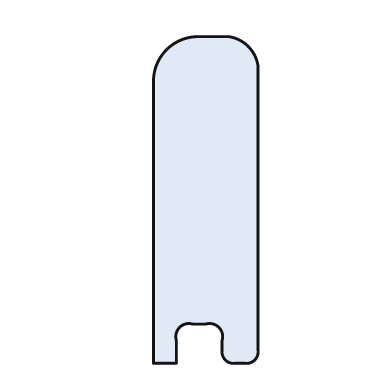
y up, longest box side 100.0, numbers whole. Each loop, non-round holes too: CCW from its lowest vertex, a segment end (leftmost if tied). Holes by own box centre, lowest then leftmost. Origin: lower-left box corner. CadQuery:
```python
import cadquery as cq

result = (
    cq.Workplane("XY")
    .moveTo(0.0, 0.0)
    .lineTo(7.0, 0.0)
    .lineTo(7.0, 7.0)
    .threePointArc((8.0, 11.0), (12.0, 12.0))
    .lineTo(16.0, 12.0)
    .threePointArc((20.0, 11.0), (21.0, 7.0))
    .lineTo(21.0, 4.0)
    .threePointArc((22.0, 1.0), (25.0, 0.0))
    .lineTo(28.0, 0.0)
    .threePointArc((31.0, 1.0), (32.0, 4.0))
    .lineTo(32.0, 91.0)
    .threePointArc((29.0, 97.0), (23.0, 100.0))
    .lineTo(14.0, 100.0)
    .threePointArc((4.0, 96.0), (0.0, 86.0))
    .close()
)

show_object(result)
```